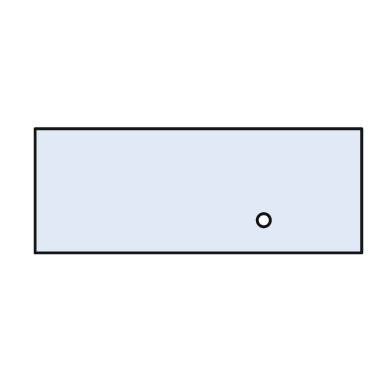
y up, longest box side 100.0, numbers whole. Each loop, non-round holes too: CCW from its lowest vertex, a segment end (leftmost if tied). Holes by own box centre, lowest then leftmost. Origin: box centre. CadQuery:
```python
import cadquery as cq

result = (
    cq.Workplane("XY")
    .moveTo(-50.0, -19.0)
    .lineTo(50.0, -19.0)
    .lineTo(50.0, 19.0)
    .lineTo(-50.0, 19.0)
    .close()
    .moveTo(20.0, -9.0)
    .circle(2.0)
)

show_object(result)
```